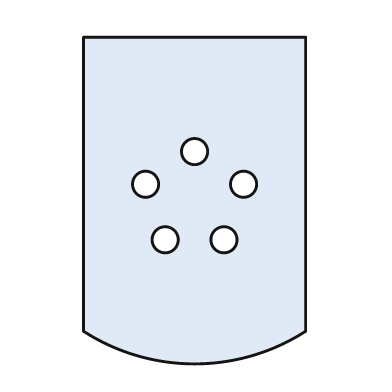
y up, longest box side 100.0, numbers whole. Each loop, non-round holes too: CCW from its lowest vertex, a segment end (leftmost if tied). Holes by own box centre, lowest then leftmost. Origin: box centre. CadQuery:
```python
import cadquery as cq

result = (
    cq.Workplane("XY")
    .moveTo(-34.0, -40.0)
    .threePointArc((0.0, -50.0), (34.0, -40.0))
    .lineTo(34.0, 50.0)
    .lineTo(-34.0, 50.0)
    .close()
    .moveTo(-9.0, -12.0)
    .circle(4.0)
    .moveTo(9.0, -12.0)
    .circle(4.0)
    .moveTo(-15.0, 5.0)
    .circle(4.0)
    .moveTo(15.0, 5.0)
    .circle(4.0)
    .moveTo(0.0, 15.0)
    .circle(4.0)
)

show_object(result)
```